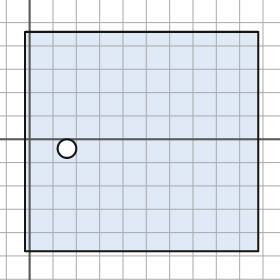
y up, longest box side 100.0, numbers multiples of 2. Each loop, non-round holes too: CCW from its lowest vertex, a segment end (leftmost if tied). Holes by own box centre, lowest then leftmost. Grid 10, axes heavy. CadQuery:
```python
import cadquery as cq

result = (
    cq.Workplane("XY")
    .moveTo(-2.0, -48.0)
    .lineTo(98.0, -48.0)
    .lineTo(98.0, 46.0)
    .lineTo(-2.0, 46.0)
    .close()
    .moveTo(16.0, -4.0)
    .circle(4.0)
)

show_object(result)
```